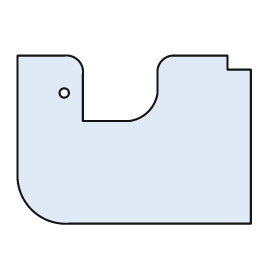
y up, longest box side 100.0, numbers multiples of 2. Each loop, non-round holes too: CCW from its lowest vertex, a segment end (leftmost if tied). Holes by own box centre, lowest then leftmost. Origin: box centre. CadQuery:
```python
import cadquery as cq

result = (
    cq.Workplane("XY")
    .moveTo(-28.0, -36.0)
    .lineTo(50.0, -36.0)
    .lineTo(50.0, 30.0)
    .lineTo(40.0, 30.0)
    .lineTo(40.0, 36.0)
    .lineTo(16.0, 36.0)
    .threePointArc((12.0, 34.0), (10.0, 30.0))
    .lineTo(10.0, 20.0)
    .threePointArc((6.0, 12.0), (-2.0, 8.0))
    .lineTo(-22.0, 8.0)
    .lineTo(-22.0, 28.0)
    .threePointArc((-24.0, 34.0), (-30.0, 36.0))
    .lineTo(-50.0, 36.0)
    .lineTo(-50.0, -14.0)
    .threePointArc((-44.0, -30.0), (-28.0, -36.0))
    .close()
    .moveTo(-30.0, 20.0)
    .circle(2.0)
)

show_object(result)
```